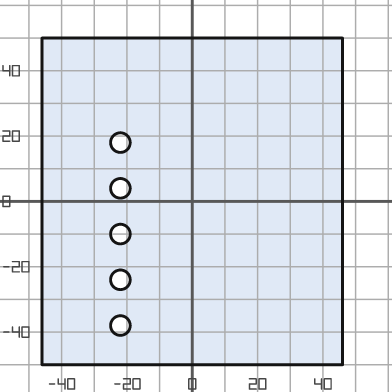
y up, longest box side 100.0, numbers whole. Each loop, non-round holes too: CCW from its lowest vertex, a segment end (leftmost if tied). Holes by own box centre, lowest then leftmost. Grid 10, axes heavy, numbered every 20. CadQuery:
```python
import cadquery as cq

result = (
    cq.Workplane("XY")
    .moveTo(-46.0, -50.0)
    .lineTo(46.0, -50.0)
    .lineTo(46.0, 50.0)
    .lineTo(-46.0, 50.0)
    .close()
    .moveTo(-22.0, -38.0)
    .circle(3.0)
    .moveTo(-22.0, -24.0)
    .circle(3.0)
    .moveTo(-22.0, -10.0)
    .circle(3.0)
    .moveTo(-22.0, 4.0)
    .circle(3.0)
    .moveTo(-22.0, 18.0)
    .circle(3.0)
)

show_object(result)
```